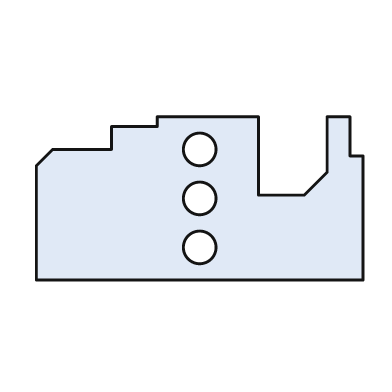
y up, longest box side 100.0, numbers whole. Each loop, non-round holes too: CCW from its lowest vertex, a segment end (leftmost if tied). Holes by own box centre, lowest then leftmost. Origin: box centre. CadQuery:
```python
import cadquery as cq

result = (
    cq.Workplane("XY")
    .moveTo(-50.0, -25.0)
    .lineTo(50.0, -25.0)
    .lineTo(50.0, 13.0)
    .lineTo(46.0, 13.0)
    .lineTo(46.0, 25.0)
    .lineTo(39.0, 25.0)
    .lineTo(39.0, 8.0)
    .lineTo(32.0, 1.0)
    .lineTo(18.0, 1.0)
    .lineTo(18.0, 25.0)
    .lineTo(-13.0, 25.0)
    .lineTo(-13.0, 22.0)
    .lineTo(-27.0, 22.0)
    .lineTo(-27.0, 15.0)
    .lineTo(-45.0, 15.0)
    .lineTo(-50.0, 10.0)
    .close()
    .moveTo(0.0, -15.0)
    .circle(5.0)
    .moveTo(0.0, 0.0)
    .circle(5.0)
    .moveTo(0.0, 15.0)
    .circle(5.0)
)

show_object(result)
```